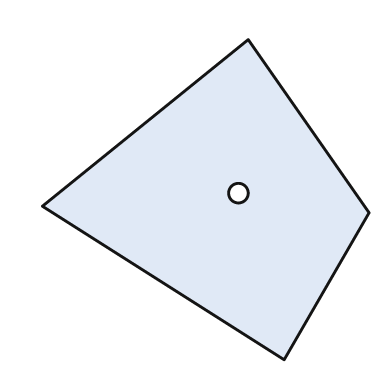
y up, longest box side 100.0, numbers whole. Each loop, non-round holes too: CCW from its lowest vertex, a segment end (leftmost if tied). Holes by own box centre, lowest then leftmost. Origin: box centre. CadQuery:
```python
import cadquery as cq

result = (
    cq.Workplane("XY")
    .moveTo(24.0, -49.0)
    .lineTo(50.0, -4.0)
    .lineTo(13.0, 49.0)
    .lineTo(-50.0, -2.0)
    .close()
    .moveTo(10.0, 2.0)
    .circle(3.0)
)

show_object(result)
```